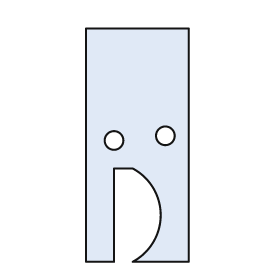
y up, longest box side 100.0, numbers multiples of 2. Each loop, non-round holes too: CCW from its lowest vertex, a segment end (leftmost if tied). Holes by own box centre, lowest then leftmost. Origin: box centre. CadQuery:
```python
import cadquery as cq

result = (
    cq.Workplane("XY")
    .moveTo(-22.0, -50.0)
    .lineTo(-10.0, -50.0)
    .lineTo(-10.0, -10.0)
    .lineTo(-2.0, -10.0)
    .threePointArc((10.0, -30.0), (-2.0, -50.0))
    .lineTo(22.0, -50.0)
    .lineTo(22.0, 50.0)
    .lineTo(-22.0, 50.0)
    .close()
    .moveTo(-10.0, 2.0)
    .circle(4.0)
    .moveTo(12.0, 4.0)
    .circle(4.0)
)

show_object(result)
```